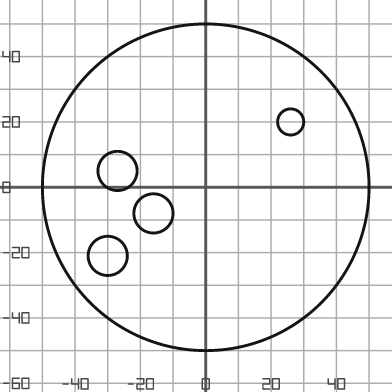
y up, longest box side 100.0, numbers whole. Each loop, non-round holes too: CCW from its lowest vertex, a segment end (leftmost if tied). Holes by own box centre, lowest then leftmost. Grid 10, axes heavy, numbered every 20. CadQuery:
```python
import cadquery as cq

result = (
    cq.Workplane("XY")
    .moveTo(0.0, 0.0)
    .circle(50.0)
    .moveTo(-30.0, -21.0)
    .circle(6.0)
    .moveTo(-16.0, -8.0)
    .circle(6.0)
    .moveTo(-27.0, 5.0)
    .circle(6.0)
    .moveTo(26.0, 20.0)
    .circle(4.0)
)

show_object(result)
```